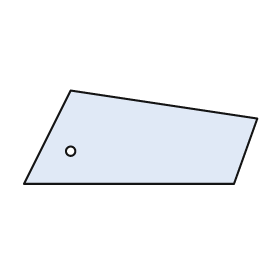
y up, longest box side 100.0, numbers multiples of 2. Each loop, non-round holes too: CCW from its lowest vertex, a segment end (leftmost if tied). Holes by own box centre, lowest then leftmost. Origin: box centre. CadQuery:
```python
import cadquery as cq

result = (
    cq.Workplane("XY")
    .moveTo(-50.0, -20.0)
    .lineTo(40.0, -20.0)
    .lineTo(50.0, 8.0)
    .lineTo(-30.0, 20.0)
    .close()
    .moveTo(-30.0, -6.0)
    .circle(2.0)
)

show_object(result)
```